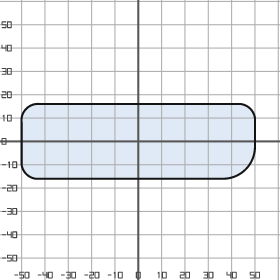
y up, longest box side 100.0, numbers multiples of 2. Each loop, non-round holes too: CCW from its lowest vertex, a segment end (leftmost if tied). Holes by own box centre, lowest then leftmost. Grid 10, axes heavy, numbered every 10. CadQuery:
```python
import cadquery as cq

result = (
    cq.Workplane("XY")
    .moveTo(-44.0, -16.0)
    .lineTo(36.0, -16.0)
    .threePointArc((46.0, -12.0), (50.0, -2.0))
    .lineTo(50.0, 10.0)
    .threePointArc((48.0, 14.0), (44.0, 16.0))
    .lineTo(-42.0, 16.0)
    .threePointArc((-48.0, 14.0), (-50.0, 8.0))
    .lineTo(-50.0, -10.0)
    .threePointArc((-48.0, -14.0), (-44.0, -16.0))
    .close()
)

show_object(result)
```